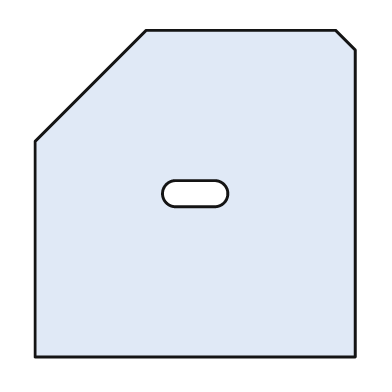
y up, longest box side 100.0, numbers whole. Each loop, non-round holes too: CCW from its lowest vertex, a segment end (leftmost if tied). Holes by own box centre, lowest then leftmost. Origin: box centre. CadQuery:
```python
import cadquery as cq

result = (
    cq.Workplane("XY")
    .moveTo(-49.0, -50.0)
    .lineTo(49.0, -50.0)
    .lineTo(49.0, 44.0)
    .lineTo(43.0, 50.0)
    .lineTo(-15.0, 50.0)
    .lineTo(-49.0, 16.0)
    .close()
    .moveTo(-6.0, -4.0)
    .lineTo(6.0, -4.0)
    .threePointArc((10.0, 0.0), (6.0, 4.0))
    .lineTo(-6.0, 4.0)
    .threePointArc((-10.0, 0.0), (-6.0, -4.0))
    .close()
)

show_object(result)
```